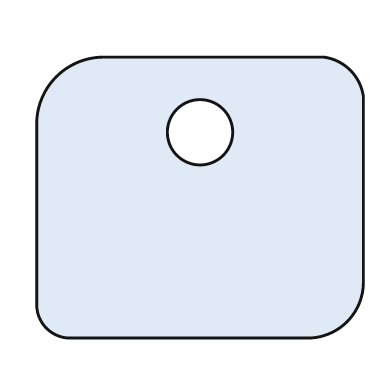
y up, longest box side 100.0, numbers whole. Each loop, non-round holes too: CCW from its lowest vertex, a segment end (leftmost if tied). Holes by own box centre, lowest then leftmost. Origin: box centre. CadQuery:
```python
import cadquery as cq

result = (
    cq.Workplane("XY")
    .moveTo(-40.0, -43.0)
    .lineTo(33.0, -43.0)
    .threePointArc((45.0, -38.0), (50.0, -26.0))
    .lineTo(50.0, 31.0)
    .threePointArc((46.0, 39.0), (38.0, 43.0))
    .lineTo(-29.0, 43.0)
    .threePointArc((-44.0, 37.0), (-50.0, 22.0))
    .lineTo(-50.0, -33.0)
    .threePointArc((-47.0, -40.0), (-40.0, -43.0))
    .close()
    .moveTo(0.0, 20.0)
    .circle(10.0)
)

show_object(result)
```